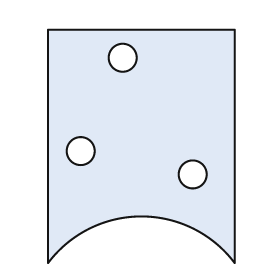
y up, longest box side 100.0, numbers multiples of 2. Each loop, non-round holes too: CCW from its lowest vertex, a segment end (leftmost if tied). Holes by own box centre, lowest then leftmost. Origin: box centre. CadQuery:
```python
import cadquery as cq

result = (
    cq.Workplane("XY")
    .moveTo(-40.0, -50.0)
    .threePointArc((0.0, -30.0), (40.0, -50.0))
    .lineTo(40.0, 50.0)
    .lineTo(-40.0, 50.0)
    .close()
    .moveTo(22.0, -12.0)
    .circle(6.0)
    .moveTo(-26.0, -2.0)
    .circle(6.0)
    .moveTo(-8.0, 38.0)
    .circle(6.0)
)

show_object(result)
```